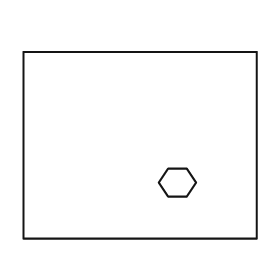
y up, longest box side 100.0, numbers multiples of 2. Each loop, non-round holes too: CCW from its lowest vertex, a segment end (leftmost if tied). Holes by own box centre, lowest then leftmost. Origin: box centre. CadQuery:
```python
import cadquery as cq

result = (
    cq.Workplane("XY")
    .moveTo(-50.0, -40.0)
    .lineTo(50.0, -40.0)
    .lineTo(50.0, 40.0)
    .lineTo(-50.0, 40.0)
    .close()
    .moveTo(12.0, -22.0)
    .lineTo(20.0, -22.0)
    .lineTo(24.0, -16.0)
    .lineTo(20.0, -10.0)
    .lineTo(12.0, -10.0)
    .lineTo(8.0, -16.0)
    .close()
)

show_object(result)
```